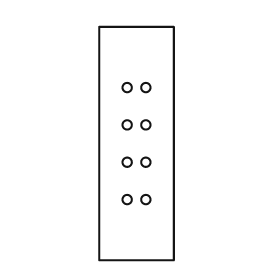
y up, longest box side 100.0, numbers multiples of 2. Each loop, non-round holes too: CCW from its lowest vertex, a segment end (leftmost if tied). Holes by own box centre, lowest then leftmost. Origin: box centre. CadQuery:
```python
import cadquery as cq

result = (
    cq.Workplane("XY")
    .moveTo(-16.0, -50.0)
    .lineTo(16.0, -50.0)
    .lineTo(16.0, 50.0)
    .lineTo(-16.0, 50.0)
    .close()
    .moveTo(-4.0, -24.0)
    .circle(2.0)
    .moveTo(4.0, -24.0)
    .circle(2.0)
    .moveTo(-4.0, -8.0)
    .circle(2.0)
    .moveTo(4.0, -8.0)
    .circle(2.0)
    .moveTo(-4.0, 8.0)
    .circle(2.0)
    .moveTo(4.0, 8.0)
    .circle(2.0)
    .moveTo(-4.0, 24.0)
    .circle(2.0)
    .moveTo(4.0, 24.0)
    .circle(2.0)
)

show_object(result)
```